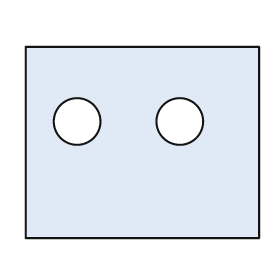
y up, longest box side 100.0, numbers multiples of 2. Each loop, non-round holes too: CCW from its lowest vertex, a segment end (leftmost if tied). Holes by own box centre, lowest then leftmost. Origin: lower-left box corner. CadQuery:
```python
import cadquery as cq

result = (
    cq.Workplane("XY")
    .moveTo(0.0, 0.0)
    .lineTo(100.0, 0.0)
    .lineTo(100.0, 82.0)
    .lineTo(0.0, 82.0)
    .close()
    .moveTo(22.0, 50.0)
    .circle(10.0)
    .moveTo(66.0, 50.0)
    .circle(10.0)
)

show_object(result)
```